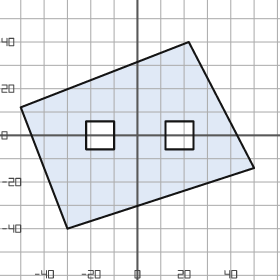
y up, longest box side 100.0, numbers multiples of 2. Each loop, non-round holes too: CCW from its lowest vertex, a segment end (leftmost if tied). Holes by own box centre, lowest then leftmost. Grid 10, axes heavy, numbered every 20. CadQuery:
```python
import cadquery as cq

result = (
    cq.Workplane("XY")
    .moveTo(-30.0, -40.0)
    .lineTo(50.0, -14.0)
    .lineTo(22.0, 40.0)
    .lineTo(-50.0, 12.0)
    .close()
    .moveTo(-22.0, -6.0)
    .lineTo(-10.0, -6.0)
    .lineTo(-10.0, 6.0)
    .lineTo(-22.0, 6.0)
    .close()
    .moveTo(12.0, -6.0)
    .lineTo(24.0, -6.0)
    .lineTo(24.0, 6.0)
    .lineTo(12.0, 6.0)
    .close()
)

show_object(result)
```